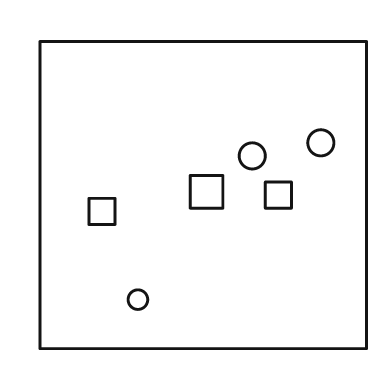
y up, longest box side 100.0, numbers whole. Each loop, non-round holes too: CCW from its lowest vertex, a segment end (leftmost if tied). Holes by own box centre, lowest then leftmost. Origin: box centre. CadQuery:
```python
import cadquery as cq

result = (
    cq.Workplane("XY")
    .moveTo(-50.0, -47.0)
    .lineTo(50.0, -47.0)
    .lineTo(50.0, 47.0)
    .lineTo(-50.0, 47.0)
    .close()
    .moveTo(-20.0, -32.0)
    .circle(3.0)
    .moveTo(-35.0, -9.0)
    .lineTo(-27.0, -9.0)
    .lineTo(-27.0, -1.0)
    .lineTo(-35.0, -1.0)
    .close()
    .moveTo(19.0, -4.0)
    .lineTo(27.0, -4.0)
    .lineTo(27.0, 4.0)
    .lineTo(19.0, 4.0)
    .close()
    .moveTo(-4.0, -4.0)
    .lineTo(6.0, -4.0)
    .lineTo(6.0, 6.0)
    .lineTo(-4.0, 6.0)
    .close()
    .moveTo(15.0, 12.0)
    .circle(4.0)
    .moveTo(36.0, 16.0)
    .circle(4.0)
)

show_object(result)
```